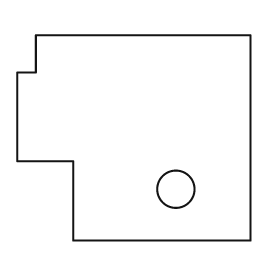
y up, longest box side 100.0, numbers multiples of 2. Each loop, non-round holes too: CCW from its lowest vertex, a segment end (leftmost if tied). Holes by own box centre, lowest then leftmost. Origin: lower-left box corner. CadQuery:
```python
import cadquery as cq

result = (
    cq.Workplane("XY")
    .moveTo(24.0, 0.0)
    .lineTo(100.0, 0.0)
    .lineTo(100.0, 88.0)
    .lineTo(8.0, 88.0)
    .lineTo(8.0, 72.0)
    .lineTo(0.0, 72.0)
    .lineTo(0.0, 34.0)
    .lineTo(24.0, 34.0)
    .close()
    .moveTo(68.0, 22.0)
    .circle(8.0)
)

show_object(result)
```